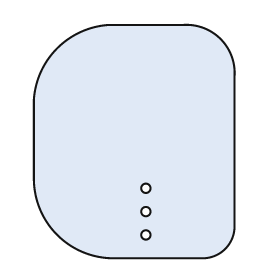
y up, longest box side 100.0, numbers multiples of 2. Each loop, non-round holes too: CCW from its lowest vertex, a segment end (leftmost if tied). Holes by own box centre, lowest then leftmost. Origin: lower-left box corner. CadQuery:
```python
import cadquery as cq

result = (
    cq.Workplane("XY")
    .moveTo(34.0, 0.0)
    .lineTo(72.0, 0.0)
    .threePointArc((82.0, 4.0), (86.0, 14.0))
    .lineTo(86.0, 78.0)
    .threePointArc((80.0, 94.0), (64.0, 100.0))
    .lineTo(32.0, 100.0)
    .threePointArc((10.0, 90.0), (0.0, 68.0))
    .lineTo(0.0, 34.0)
    .threePointArc((10.0, 10.0), (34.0, 0.0))
    .close()
    .moveTo(48.0, 10.0)
    .circle(2.0)
    .moveTo(48.0, 20.0)
    .circle(2.0)
    .moveTo(48.0, 30.0)
    .circle(2.0)
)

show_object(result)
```